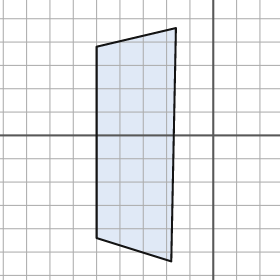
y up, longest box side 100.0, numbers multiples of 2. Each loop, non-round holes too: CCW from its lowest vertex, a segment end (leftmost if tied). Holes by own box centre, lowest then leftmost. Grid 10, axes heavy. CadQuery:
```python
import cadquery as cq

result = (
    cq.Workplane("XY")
    .moveTo(-18.0, -54.0)
    .lineTo(-16.0, 46.0)
    .lineTo(-50.0, 38.0)
    .lineTo(-50.0, -44.0)
    .close()
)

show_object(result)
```